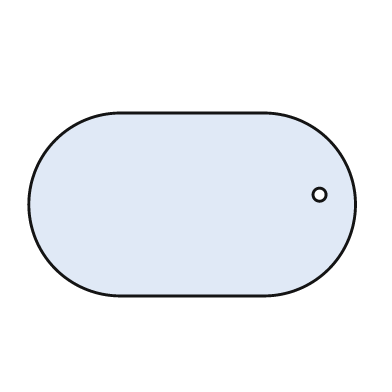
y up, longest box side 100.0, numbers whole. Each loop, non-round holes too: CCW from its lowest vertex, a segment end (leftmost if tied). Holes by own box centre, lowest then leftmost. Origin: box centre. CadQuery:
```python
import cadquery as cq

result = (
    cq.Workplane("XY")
    .moveTo(-22.0, -28.0)
    .lineTo(22.0, -28.0)
    .threePointArc((50.0, 0.0), (22.0, 28.0))
    .lineTo(-22.0, 28.0)
    .threePointArc((-50.0, 0.0), (-22.0, -28.0))
    .close()
    .moveTo(39.0, 3.0)
    .circle(2.0)
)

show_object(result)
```